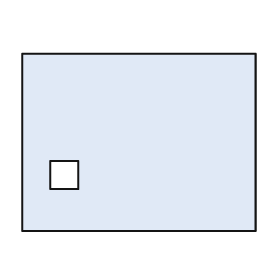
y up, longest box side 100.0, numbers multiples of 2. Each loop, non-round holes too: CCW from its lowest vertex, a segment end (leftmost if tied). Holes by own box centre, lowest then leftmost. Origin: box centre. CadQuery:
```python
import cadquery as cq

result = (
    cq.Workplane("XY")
    .moveTo(-50.0, -38.0)
    .lineTo(50.0, -38.0)
    .lineTo(50.0, 38.0)
    .lineTo(-50.0, 38.0)
    .close()
    .moveTo(-38.0, -20.0)
    .lineTo(-26.0, -20.0)
    .lineTo(-26.0, -8.0)
    .lineTo(-38.0, -8.0)
    .close()
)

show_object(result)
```